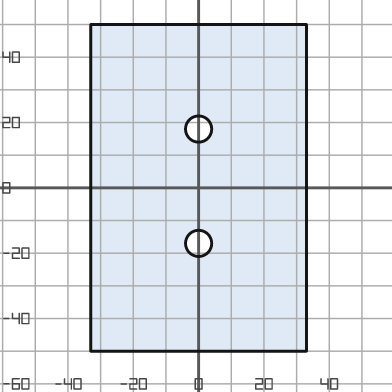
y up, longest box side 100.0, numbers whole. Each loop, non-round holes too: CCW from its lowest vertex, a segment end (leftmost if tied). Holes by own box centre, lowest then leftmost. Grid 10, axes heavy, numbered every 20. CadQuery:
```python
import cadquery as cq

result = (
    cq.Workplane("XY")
    .moveTo(-33.0, -50.0)
    .lineTo(33.0, -50.0)
    .lineTo(33.0, 50.0)
    .lineTo(-33.0, 50.0)
    .close()
    .moveTo(0.0, -17.0)
    .circle(4.0)
    .moveTo(0.0, 18.0)
    .circle(4.0)
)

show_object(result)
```